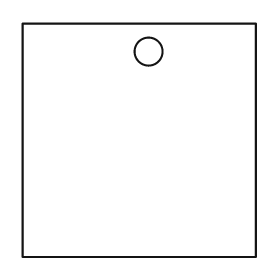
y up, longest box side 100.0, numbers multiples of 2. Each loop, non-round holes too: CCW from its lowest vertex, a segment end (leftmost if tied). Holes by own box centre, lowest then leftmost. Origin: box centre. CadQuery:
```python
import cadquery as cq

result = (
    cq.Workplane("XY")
    .moveTo(-50.0, -50.0)
    .lineTo(50.0, -50.0)
    .lineTo(50.0, 50.0)
    .lineTo(-50.0, 50.0)
    .close()
    .moveTo(4.0, 38.0)
    .circle(6.0)
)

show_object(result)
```